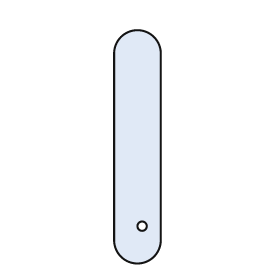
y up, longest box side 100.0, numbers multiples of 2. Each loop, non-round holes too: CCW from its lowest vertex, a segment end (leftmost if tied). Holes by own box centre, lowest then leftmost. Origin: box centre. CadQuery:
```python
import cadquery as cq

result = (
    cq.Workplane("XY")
    .moveTo(-10.0, -40.0)
    .threePointArc((0.0, -50.0), (10.0, -40.0))
    .lineTo(10.0, 40.0)
    .threePointArc((0.0, 50.0), (-10.0, 40.0))
    .close()
    .moveTo(2.0, -34.0)
    .circle(2.0)
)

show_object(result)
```